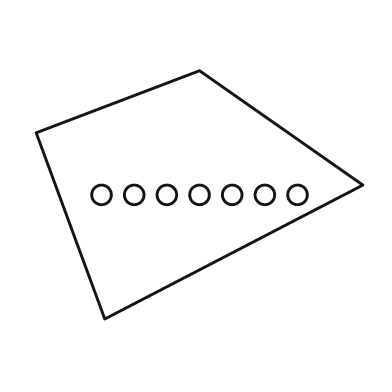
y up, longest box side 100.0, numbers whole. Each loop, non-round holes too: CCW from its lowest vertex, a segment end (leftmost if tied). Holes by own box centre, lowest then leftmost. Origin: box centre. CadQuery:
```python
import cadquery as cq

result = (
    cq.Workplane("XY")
    .moveTo(-29.0, -38.0)
    .lineTo(50.0, 3.0)
    .lineTo(0.0, 38.0)
    .lineTo(-50.0, 19.0)
    .close()
    .moveTo(-30.0, 0.0)
    .circle(3.0)
    .moveTo(-20.0, 0.0)
    .circle(3.0)
    .moveTo(-10.0, 0.0)
    .circle(3.0)
    .moveTo(0.0, 0.0)
    .circle(3.0)
    .moveTo(10.0, 0.0)
    .circle(3.0)
    .moveTo(20.0, 0.0)
    .circle(3.0)
    .moveTo(30.0, 0.0)
    .circle(3.0)
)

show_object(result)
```